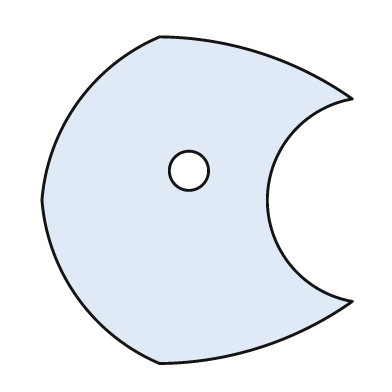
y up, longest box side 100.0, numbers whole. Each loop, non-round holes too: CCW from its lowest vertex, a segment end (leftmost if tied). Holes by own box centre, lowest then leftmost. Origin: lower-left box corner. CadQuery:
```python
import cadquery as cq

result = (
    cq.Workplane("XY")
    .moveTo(36.0, 0.0)
    .threePointArc((67.0, 5.0), (95.0, 19.0))
    .threePointArc((69.0, 50.0), (95.0, 81.0))
    .threePointArc((67.0, 95.0), (36.0, 100.0))
    .threePointArc((11.0, 80.0), (0.0, 50.0))
    .threePointArc((11.0, 20.0), (36.0, 0.0))
    .close()
    .moveTo(45.0, 59.0)
    .circle(6.0)
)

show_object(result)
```